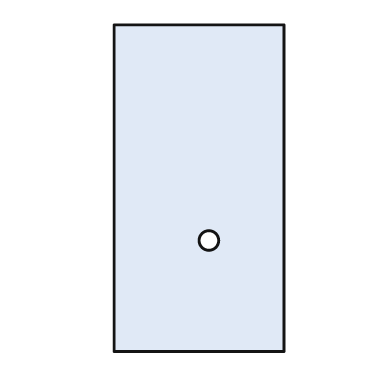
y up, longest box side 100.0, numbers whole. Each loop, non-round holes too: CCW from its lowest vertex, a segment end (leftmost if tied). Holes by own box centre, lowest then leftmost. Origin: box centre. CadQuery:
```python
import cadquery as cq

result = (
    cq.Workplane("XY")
    .moveTo(-26.0, -50.0)
    .lineTo(26.0, -50.0)
    .lineTo(26.0, 50.0)
    .lineTo(-26.0, 50.0)
    .close()
    .moveTo(3.0, -16.0)
    .circle(3.0)
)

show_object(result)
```